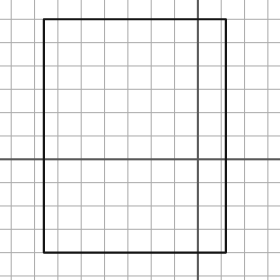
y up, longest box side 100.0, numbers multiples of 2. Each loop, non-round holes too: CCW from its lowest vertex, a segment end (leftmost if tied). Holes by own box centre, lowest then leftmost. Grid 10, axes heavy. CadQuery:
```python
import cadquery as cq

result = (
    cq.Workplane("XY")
    .moveTo(-66.0, -40.0)
    .lineTo(12.0, -40.0)
    .lineTo(12.0, 60.0)
    .lineTo(-66.0, 60.0)
    .close()
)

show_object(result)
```